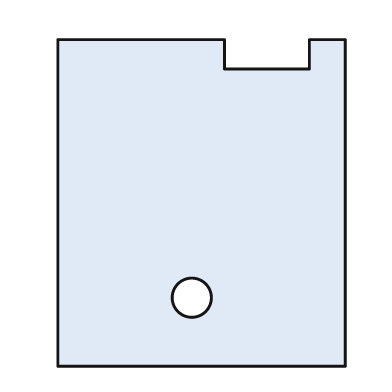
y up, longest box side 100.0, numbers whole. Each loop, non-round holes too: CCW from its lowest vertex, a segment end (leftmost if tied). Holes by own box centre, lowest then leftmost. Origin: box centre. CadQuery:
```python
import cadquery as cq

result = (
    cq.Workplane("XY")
    .moveTo(-44.0, -50.0)
    .lineTo(44.0, -50.0)
    .lineTo(44.0, 50.0)
    .lineTo(33.0, 50.0)
    .lineTo(33.0, 41.0)
    .lineTo(7.0, 41.0)
    .lineTo(7.0, 50.0)
    .lineTo(-44.0, 50.0)
    .close()
    .moveTo(-3.0, -29.0)
    .circle(6.0)
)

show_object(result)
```